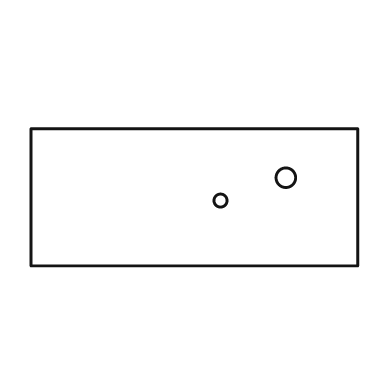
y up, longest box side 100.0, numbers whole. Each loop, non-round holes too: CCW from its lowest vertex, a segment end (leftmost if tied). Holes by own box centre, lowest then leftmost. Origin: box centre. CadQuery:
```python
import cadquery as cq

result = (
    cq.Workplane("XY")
    .moveTo(-50.0, -21.0)
    .lineTo(50.0, -21.0)
    .lineTo(50.0, 21.0)
    .lineTo(-50.0, 21.0)
    .close()
    .moveTo(8.0, -1.0)
    .circle(2.0)
    .moveTo(28.0, 6.0)
    .circle(3.0)
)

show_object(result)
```